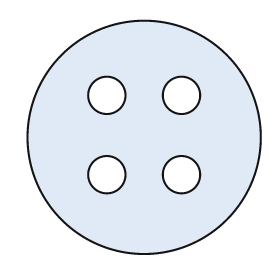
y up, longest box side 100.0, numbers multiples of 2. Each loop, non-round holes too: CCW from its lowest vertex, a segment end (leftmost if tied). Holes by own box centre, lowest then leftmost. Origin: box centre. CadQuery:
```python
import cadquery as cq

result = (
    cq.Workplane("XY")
    .moveTo(0.0, 0.0)
    .circle(50.0)
    .moveTo(-16.0, -16.0)
    .circle(8.0)
    .moveTo(16.0, -16.0)
    .circle(8.0)
    .moveTo(-16.0, 18.0)
    .circle(8.0)
    .moveTo(16.0, 18.0)
    .circle(8.0)
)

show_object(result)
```